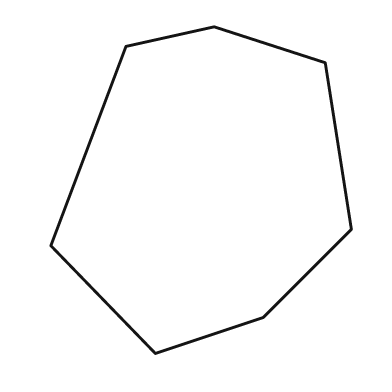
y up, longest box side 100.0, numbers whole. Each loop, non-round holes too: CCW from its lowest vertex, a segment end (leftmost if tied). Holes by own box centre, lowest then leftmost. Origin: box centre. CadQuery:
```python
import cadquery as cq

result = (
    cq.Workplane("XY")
    .moveTo(-14.0, -50.0)
    .lineTo(19.0, -39.0)
    .lineTo(46.0, -12.0)
    .lineTo(38.0, 39.0)
    .lineTo(4.0, 50.0)
    .lineTo(-23.0, 44.0)
    .lineTo(-46.0, -17.0)
    .close()
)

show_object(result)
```